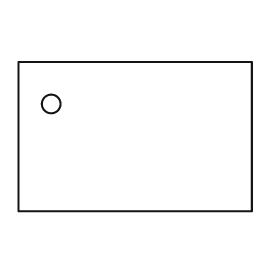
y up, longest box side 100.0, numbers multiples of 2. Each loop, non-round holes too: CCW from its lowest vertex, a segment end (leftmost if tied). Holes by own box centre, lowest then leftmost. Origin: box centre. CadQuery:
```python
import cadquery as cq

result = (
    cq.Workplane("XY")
    .moveTo(-50.0, -32.0)
    .lineTo(50.0, -32.0)
    .lineTo(50.0, 32.0)
    .lineTo(-50.0, 32.0)
    .close()
    .moveTo(-36.0, 14.0)
    .circle(4.0)
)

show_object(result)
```